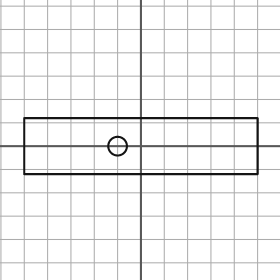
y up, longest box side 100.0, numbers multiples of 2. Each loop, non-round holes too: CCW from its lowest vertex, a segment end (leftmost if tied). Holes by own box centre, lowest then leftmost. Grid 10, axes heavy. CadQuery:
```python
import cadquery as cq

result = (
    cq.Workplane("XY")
    .moveTo(-50.0, -12.0)
    .lineTo(50.0, -12.0)
    .lineTo(50.0, 12.0)
    .lineTo(-50.0, 12.0)
    .close()
    .moveTo(-10.0, 0.0)
    .circle(4.0)
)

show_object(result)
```